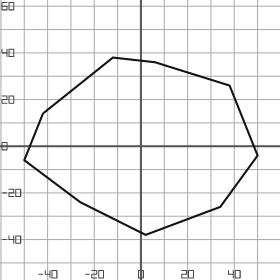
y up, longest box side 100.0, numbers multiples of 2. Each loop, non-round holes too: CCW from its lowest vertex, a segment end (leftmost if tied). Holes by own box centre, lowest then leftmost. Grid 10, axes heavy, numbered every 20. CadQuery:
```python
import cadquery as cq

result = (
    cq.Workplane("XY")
    .moveTo(2.0, -38.0)
    .lineTo(34.0, -26.0)
    .lineTo(50.0, -4.0)
    .lineTo(38.0, 26.0)
    .lineTo(6.0, 36.0)
    .lineTo(-12.0, 38.0)
    .lineTo(-42.0, 14.0)
    .lineTo(-50.0, -6.0)
    .lineTo(-26.0, -24.0)
    .close()
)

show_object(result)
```